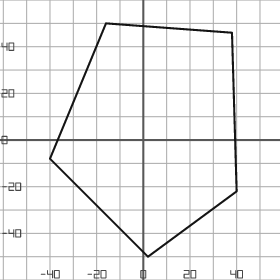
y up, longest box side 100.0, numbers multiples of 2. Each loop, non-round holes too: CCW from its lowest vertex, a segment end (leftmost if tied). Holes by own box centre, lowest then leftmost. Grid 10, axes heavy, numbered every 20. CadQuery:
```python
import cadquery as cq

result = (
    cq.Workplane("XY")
    .moveTo(2.0, -50.0)
    .lineTo(40.0, -22.0)
    .lineTo(38.0, 46.0)
    .lineTo(-16.0, 50.0)
    .lineTo(-40.0, -8.0)
    .close()
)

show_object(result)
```